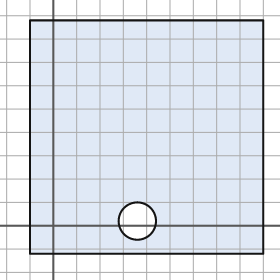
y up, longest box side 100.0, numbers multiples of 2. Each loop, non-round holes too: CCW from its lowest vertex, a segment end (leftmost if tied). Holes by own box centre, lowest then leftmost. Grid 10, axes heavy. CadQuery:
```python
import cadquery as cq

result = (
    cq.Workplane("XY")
    .moveTo(-10.0, -12.0)
    .lineTo(90.0, -12.0)
    .lineTo(90.0, 88.0)
    .lineTo(-10.0, 88.0)
    .close()
    .moveTo(36.0, 2.0)
    .circle(8.0)
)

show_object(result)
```